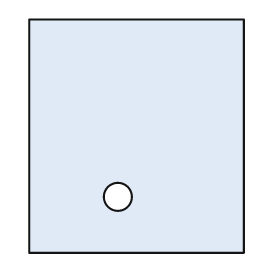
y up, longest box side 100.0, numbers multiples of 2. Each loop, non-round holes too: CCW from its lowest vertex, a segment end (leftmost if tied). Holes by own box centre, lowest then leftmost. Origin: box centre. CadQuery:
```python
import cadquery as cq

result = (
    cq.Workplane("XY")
    .moveTo(-46.0, -50.0)
    .lineTo(46.0, -50.0)
    .lineTo(46.0, 50.0)
    .lineTo(-46.0, 50.0)
    .close()
    .moveTo(-8.0, -26.0)
    .circle(6.0)
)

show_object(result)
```